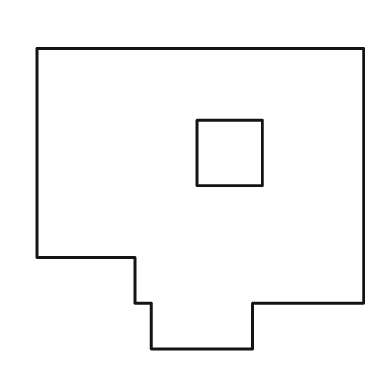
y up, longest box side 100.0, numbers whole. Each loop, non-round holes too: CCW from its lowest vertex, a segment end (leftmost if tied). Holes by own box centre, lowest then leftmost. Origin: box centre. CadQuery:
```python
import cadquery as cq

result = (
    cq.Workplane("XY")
    .moveTo(-15.0, -46.0)
    .lineTo(16.0, -46.0)
    .lineTo(16.0, -32.0)
    .lineTo(50.0, -32.0)
    .lineTo(50.0, 46.0)
    .lineTo(-50.0, 46.0)
    .lineTo(-50.0, -18.0)
    .lineTo(-20.0, -18.0)
    .lineTo(-20.0, -32.0)
    .lineTo(-15.0, -32.0)
    .close()
    .moveTo(-1.0, 4.0)
    .lineTo(19.0, 4.0)
    .lineTo(19.0, 24.0)
    .lineTo(-1.0, 24.0)
    .close()
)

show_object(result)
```